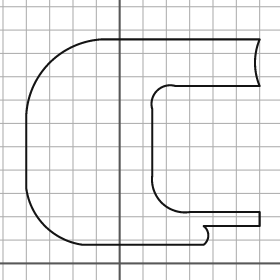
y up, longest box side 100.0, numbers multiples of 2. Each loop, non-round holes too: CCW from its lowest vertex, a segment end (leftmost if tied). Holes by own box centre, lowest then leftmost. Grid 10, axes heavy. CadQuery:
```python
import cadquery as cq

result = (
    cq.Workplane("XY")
    .moveTo(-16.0, 8.0)
    .lineTo(36.0, 8.0)
    .threePointArc((38.0, 12.0), (36.0, 16.0))
    .lineTo(60.0, 16.0)
    .lineTo(60.0, 22.0)
    .lineTo(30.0, 22.0)
    .threePointArc((18.0, 26.0), (14.0, 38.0))
    .lineTo(14.0, 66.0)
    .threePointArc((16.0, 74.0), (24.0, 76.0))
    .lineTo(60.0, 76.0)
    .threePointArc((58.0, 86.0), (60.0, 96.0))
    .lineTo(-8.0, 96.0)
    .threePointArc((-30.0, 86.0), (-40.0, 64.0))
    .lineTo(-40.0, 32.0)
    .threePointArc((-32.0, 16.0), (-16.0, 8.0))
    .close()
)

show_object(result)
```